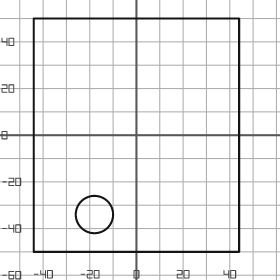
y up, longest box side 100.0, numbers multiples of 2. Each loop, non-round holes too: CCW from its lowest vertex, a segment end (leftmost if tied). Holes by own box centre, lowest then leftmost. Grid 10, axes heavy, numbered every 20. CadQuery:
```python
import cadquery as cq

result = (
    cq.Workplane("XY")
    .moveTo(-44.0, -50.0)
    .lineTo(44.0, -50.0)
    .lineTo(44.0, 50.0)
    .lineTo(-44.0, 50.0)
    .close()
    .moveTo(-18.0, -34.0)
    .circle(8.0)
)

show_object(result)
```